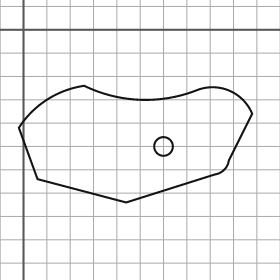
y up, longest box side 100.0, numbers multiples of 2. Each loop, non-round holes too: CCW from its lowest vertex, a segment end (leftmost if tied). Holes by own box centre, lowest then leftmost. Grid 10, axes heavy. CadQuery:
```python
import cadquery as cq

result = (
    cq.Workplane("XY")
    .moveTo(44.0, -74.0)
    .lineTo(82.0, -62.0)
    .threePointArc((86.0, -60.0), (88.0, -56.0))
    .lineTo(98.0, -36.0)
    .threePointArc((88.0, -26.0), (74.0, -26.0))
    .threePointArc((50.0, -30.0), (26.0, -24.0))
    .threePointArc((10.0, -30.0), (-2.0, -42.0))
    .lineTo(6.0, -64.0)
    .close()
    .moveTo(60.0, -50.0)
    .circle(4.0)
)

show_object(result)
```